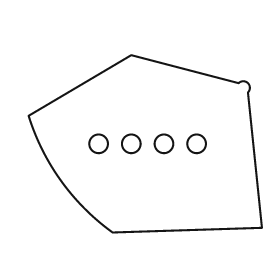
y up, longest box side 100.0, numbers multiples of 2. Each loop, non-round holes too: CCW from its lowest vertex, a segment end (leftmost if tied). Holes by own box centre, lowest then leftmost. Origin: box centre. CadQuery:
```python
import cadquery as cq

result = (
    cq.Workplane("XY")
    .moveTo(-14.0, -38.0)
    .lineTo(50.0, -36.0)
    .lineTo(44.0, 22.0)
    .threePointArc((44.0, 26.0), (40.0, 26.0))
    .lineTo(-6.0, 38.0)
    .lineTo(-50.0, 12.0)
    .threePointArc((-36.0, -16.0), (-14.0, -38.0))
    .close()
    .moveTo(-20.0, 0.0)
    .circle(4.0)
    .moveTo(-6.0, 0.0)
    .circle(4.0)
    .moveTo(8.0, 0.0)
    .circle(4.0)
    .moveTo(22.0, 0.0)
    .circle(4.0)
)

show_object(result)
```